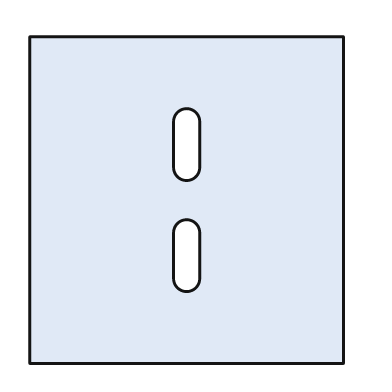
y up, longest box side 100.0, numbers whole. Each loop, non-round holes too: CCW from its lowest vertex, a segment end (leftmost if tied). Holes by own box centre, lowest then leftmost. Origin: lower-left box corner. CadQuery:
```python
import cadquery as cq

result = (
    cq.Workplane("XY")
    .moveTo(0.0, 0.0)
    .lineTo(96.0, 0.0)
    .lineTo(96.0, 100.0)
    .lineTo(0.0, 100.0)
    .close()
    .moveTo(44.0, 26.0)
    .threePointArc((48.0, 22.0), (52.0, 26.0))
    .lineTo(52.0, 40.0)
    .threePointArc((48.0, 44.0), (44.0, 40.0))
    .close()
    .moveTo(44.0, 60.0)
    .threePointArc((48.0, 56.0), (52.0, 60.0))
    .lineTo(52.0, 74.0)
    .threePointArc((48.0, 78.0), (44.0, 74.0))
    .close()
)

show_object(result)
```